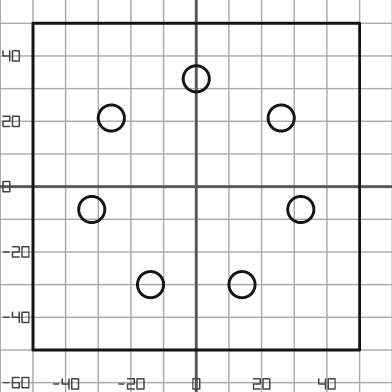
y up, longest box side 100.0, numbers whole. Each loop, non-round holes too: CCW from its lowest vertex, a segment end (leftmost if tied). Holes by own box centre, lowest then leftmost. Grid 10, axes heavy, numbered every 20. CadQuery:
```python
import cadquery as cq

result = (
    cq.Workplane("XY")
    .moveTo(-50.0, -50.0)
    .lineTo(50.0, -50.0)
    .lineTo(50.0, 50.0)
    .lineTo(-50.0, 50.0)
    .close()
    .moveTo(-14.0, -30.0)
    .circle(4.0)
    .moveTo(14.0, -30.0)
    .circle(4.0)
    .moveTo(-32.0, -7.0)
    .circle(4.0)
    .moveTo(32.0, -7.0)
    .circle(4.0)
    .moveTo(-26.0, 21.0)
    .circle(4.0)
    .moveTo(26.0, 21.0)
    .circle(4.0)
    .moveTo(0.0, 33.0)
    .circle(4.0)
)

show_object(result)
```